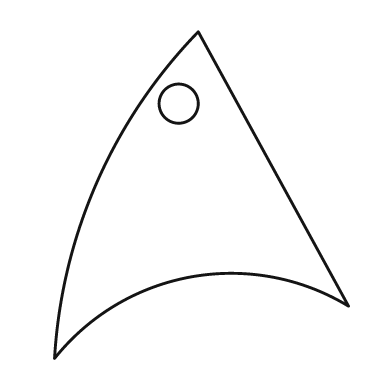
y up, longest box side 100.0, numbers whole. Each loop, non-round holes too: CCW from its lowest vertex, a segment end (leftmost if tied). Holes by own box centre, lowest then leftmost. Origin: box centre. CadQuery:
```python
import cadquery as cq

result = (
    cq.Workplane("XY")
    .moveTo(-45.0, -50.0)
    .threePointArc((-3.0, -25.0), (45.0, -34.0))
    .lineTo(-1.0, 50.0)
    .threePointArc((-32.0, 4.0), (-45.0, -50.0))
    .close()
    .moveTo(-7.0, 28.0)
    .circle(6.0)
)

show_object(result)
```